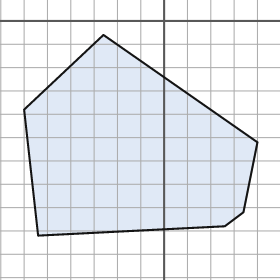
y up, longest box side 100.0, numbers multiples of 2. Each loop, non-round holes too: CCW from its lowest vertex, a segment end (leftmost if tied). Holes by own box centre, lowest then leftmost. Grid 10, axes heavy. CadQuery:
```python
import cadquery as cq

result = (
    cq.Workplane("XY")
    .moveTo(-54.0, -92.0)
    .lineTo(26.0, -88.0)
    .lineTo(34.0, -82.0)
    .lineTo(40.0, -52.0)
    .lineTo(-26.0, -6.0)
    .lineTo(-60.0, -38.0)
    .close()
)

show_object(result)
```